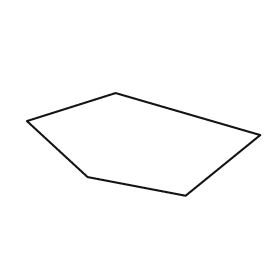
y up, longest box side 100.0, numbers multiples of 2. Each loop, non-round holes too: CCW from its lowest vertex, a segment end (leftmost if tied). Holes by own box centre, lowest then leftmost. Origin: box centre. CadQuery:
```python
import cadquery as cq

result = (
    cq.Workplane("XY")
    .moveTo(18.0, -22.0)
    .lineTo(50.0, 4.0)
    .lineTo(-12.0, 22.0)
    .lineTo(-50.0, 10.0)
    .lineTo(-24.0, -14.0)
    .close()
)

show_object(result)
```